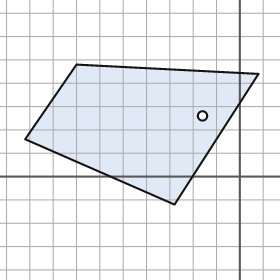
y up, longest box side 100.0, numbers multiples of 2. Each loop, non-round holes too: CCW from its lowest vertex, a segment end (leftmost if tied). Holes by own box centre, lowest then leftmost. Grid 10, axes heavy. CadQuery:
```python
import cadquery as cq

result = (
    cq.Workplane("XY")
    .moveTo(-28.0, -12.0)
    .lineTo(8.0, 44.0)
    .lineTo(-70.0, 48.0)
    .lineTo(-92.0, 16.0)
    .close()
    .moveTo(-16.0, 26.0)
    .circle(2.0)
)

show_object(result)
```